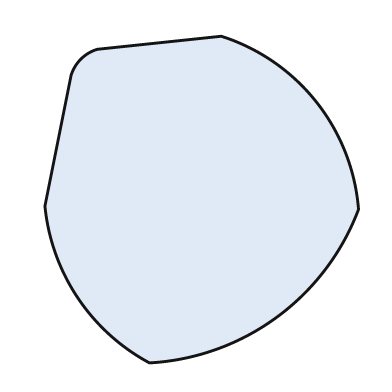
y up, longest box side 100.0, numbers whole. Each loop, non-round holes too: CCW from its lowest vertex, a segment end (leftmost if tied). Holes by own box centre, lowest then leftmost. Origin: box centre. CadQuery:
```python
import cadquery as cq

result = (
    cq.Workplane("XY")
    .moveTo(-16.0, -50.0)
    .threePointArc((23.0, -36.0), (48.0, -3.0))
    .threePointArc((35.0, 30.0), (6.0, 50.0))
    .lineTo(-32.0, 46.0)
    .threePointArc((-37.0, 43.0), (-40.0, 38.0))
    .lineTo(-48.0, -2.0)
    .threePointArc((-38.0, -30.0), (-16.0, -50.0))
    .close()
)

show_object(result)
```